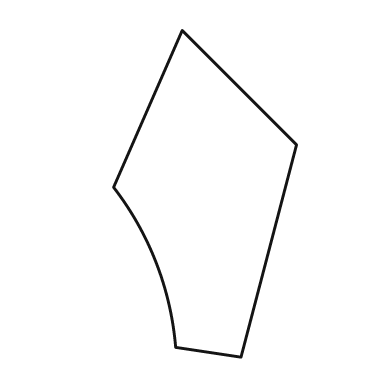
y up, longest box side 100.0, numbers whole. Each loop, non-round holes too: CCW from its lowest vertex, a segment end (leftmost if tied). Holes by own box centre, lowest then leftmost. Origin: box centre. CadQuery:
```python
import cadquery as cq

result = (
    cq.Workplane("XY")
    .moveTo(11.0, -50.0)
    .lineTo(28.0, 15.0)
    .lineTo(-7.0, 50.0)
    .lineTo(-28.0, 2.0)
    .threePointArc((-15.0, -21.0), (-9.0, -47.0))
    .close()
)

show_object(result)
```